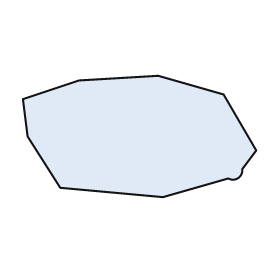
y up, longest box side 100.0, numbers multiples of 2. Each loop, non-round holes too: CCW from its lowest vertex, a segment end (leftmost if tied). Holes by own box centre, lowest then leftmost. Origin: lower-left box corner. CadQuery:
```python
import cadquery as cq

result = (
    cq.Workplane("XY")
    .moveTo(60.0, 0.0)
    .lineTo(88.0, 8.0)
    .threePointArc((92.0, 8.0), (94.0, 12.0))
    .lineTo(100.0, 20.0)
    .lineTo(86.0, 44.0)
    .lineTo(58.0, 52.0)
    .lineTo(24.0, 50.0)
    .lineTo(0.0, 42.0)
    .lineTo(2.0, 26.0)
    .lineTo(16.0, 4.0)
    .close()
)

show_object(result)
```